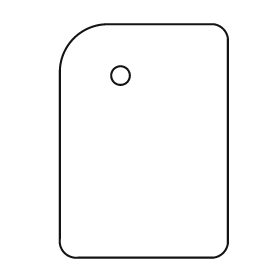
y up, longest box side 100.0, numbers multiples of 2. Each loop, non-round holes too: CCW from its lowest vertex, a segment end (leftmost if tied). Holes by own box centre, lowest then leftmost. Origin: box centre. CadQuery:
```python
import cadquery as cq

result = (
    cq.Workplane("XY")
    .moveTo(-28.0, -50.0)
    .lineTo(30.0, -50.0)
    .threePointArc((34.0, -48.0), (36.0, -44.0))
    .lineTo(36.0, 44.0)
    .threePointArc((34.0, 48.0), (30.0, 50.0))
    .lineTo(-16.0, 50.0)
    .threePointArc((-30.0, 44.0), (-36.0, 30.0))
    .lineTo(-36.0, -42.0)
    .threePointArc((-34.0, -48.0), (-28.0, -50.0))
    .close()
    .moveTo(-10.0, 28.0)
    .circle(4.0)
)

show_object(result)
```